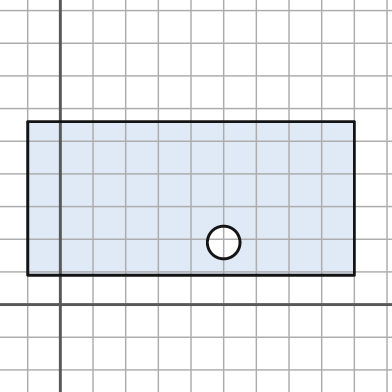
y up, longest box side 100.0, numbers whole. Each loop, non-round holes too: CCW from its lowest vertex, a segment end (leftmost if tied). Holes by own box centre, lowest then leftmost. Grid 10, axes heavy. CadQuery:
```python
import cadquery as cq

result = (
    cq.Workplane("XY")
    .moveTo(-10.0, 9.0)
    .lineTo(90.0, 9.0)
    .lineTo(90.0, 56.0)
    .lineTo(-10.0, 56.0)
    .close()
    .moveTo(50.0, 19.0)
    .circle(5.0)
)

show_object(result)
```